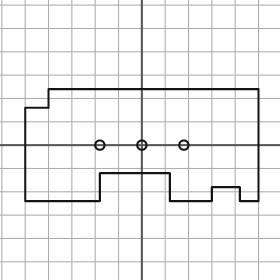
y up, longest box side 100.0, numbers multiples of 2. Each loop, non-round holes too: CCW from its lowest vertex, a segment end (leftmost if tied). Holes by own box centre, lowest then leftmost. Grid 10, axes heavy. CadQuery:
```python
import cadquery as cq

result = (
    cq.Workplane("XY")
    .moveTo(-50.0, -24.0)
    .lineTo(-18.0, -24.0)
    .lineTo(-18.0, -12.0)
    .lineTo(12.0, -12.0)
    .lineTo(12.0, -24.0)
    .lineTo(30.0, -24.0)
    .lineTo(30.0, -18.0)
    .lineTo(42.0, -18.0)
    .lineTo(42.0, -24.0)
    .lineTo(50.0, -24.0)
    .lineTo(50.0, 24.0)
    .lineTo(-40.0, 24.0)
    .lineTo(-40.0, 16.0)
    .lineTo(-50.0, 16.0)
    .close()
    .moveTo(-18.0, 0.0)
    .circle(2.0)
    .moveTo(0.0, 0.0)
    .circle(2.0)
    .moveTo(18.0, 0.0)
    .circle(2.0)
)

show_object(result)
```